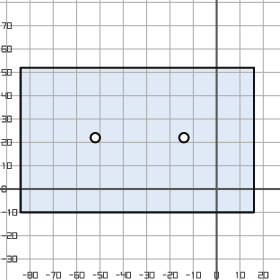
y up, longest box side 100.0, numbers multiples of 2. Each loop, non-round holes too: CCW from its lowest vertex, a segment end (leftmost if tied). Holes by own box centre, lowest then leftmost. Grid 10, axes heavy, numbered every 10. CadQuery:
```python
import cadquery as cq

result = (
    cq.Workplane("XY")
    .moveTo(-84.0, -10.0)
    .lineTo(16.0, -10.0)
    .lineTo(16.0, 52.0)
    .lineTo(-84.0, 52.0)
    .close()
    .moveTo(-52.0, 22.0)
    .circle(2.0)
    .moveTo(-14.0, 22.0)
    .circle(2.0)
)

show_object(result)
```